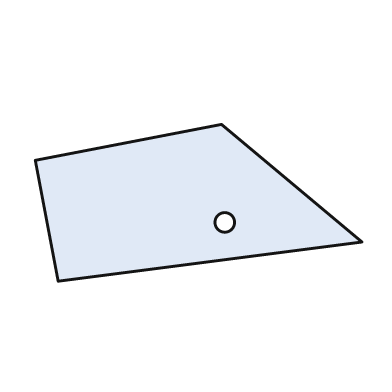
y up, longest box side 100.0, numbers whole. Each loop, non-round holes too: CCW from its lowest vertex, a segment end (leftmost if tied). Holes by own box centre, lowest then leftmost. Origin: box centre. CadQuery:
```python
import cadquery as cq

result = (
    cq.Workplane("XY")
    .moveTo(-43.0, -24.0)
    .lineTo(50.0, -12.0)
    .lineTo(7.0, 24.0)
    .lineTo(-50.0, 13.0)
    .close()
    .moveTo(8.0, -6.0)
    .circle(3.0)
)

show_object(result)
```